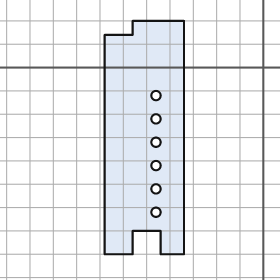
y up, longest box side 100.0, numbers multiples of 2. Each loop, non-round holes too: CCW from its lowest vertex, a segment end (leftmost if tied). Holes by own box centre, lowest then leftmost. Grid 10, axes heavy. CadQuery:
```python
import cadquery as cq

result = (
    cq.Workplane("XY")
    .moveTo(-68.0, -80.0)
    .lineTo(-56.0, -80.0)
    .lineTo(-56.0, -70.0)
    .lineTo(-44.0, -70.0)
    .lineTo(-44.0, -80.0)
    .lineTo(-34.0, -80.0)
    .lineTo(-34.0, 20.0)
    .lineTo(-56.0, 20.0)
    .lineTo(-56.0, 14.0)
    .lineTo(-68.0, 14.0)
    .close()
    .moveTo(-46.0, -62.0)
    .circle(2.0)
    .moveTo(-46.0, -52.0)
    .circle(2.0)
    .moveTo(-46.0, -42.0)
    .circle(2.0)
    .moveTo(-46.0, -32.0)
    .circle(2.0)
    .moveTo(-46.0, -22.0)
    .circle(2.0)
    .moveTo(-46.0, -12.0)
    .circle(2.0)
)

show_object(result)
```